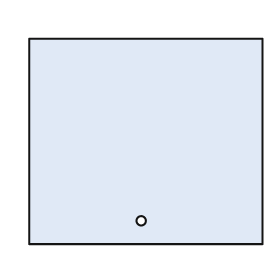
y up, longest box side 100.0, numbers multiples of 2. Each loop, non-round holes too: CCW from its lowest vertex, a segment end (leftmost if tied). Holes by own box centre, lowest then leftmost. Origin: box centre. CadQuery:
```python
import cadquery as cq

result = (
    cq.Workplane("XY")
    .moveTo(-50.0, -44.0)
    .lineTo(50.0, -44.0)
    .lineTo(50.0, 44.0)
    .lineTo(-50.0, 44.0)
    .close()
    .moveTo(-2.0, -34.0)
    .circle(2.0)
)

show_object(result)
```